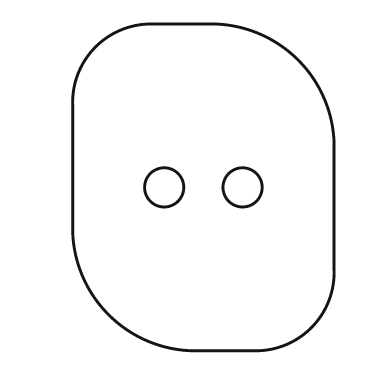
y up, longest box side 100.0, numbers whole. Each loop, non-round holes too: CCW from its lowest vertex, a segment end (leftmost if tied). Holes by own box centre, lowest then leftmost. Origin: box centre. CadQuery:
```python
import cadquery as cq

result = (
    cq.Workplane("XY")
    .moveTo(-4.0, -50.0)
    .lineTo(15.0, -50.0)
    .threePointArc((33.0, -43.0), (40.0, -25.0))
    .lineTo(40.0, 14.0)
    .threePointArc((29.0, 39.0), (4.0, 50.0))
    .lineTo(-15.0, 50.0)
    .threePointArc((-33.0, 43.0), (-40.0, 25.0))
    .lineTo(-40.0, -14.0)
    .threePointArc((-29.0, -39.0), (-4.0, -50.0))
    .close()
    .moveTo(-12.0, 0.0)
    .circle(6.0)
    .moveTo(12.0, 0.0)
    .circle(6.0)
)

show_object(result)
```